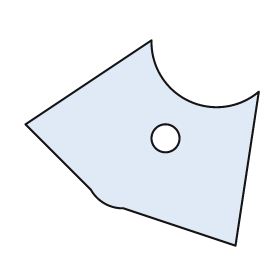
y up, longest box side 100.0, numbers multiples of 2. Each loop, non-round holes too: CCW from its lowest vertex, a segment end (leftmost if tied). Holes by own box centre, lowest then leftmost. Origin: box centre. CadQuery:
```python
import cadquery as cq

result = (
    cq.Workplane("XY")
    .moveTo(40.0, -44.0)
    .lineTo(50.0, 22.0)
    .threePointArc((20.0, 18.0), (4.0, 44.0))
    .lineTo(-50.0, 8.0)
    .lineTo(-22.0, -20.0)
    .threePointArc((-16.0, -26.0), (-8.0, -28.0))
    .close()
    .moveTo(10.0, 2.0)
    .circle(6.0)
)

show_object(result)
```